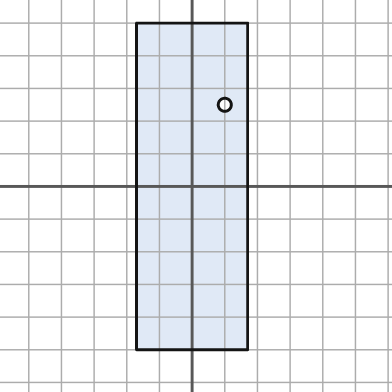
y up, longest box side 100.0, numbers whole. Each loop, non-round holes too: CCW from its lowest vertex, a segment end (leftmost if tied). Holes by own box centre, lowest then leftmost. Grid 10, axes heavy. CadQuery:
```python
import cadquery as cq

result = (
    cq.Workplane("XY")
    .moveTo(-17.0, -50.0)
    .lineTo(17.0, -50.0)
    .lineTo(17.0, 50.0)
    .lineTo(-17.0, 50.0)
    .close()
    .moveTo(10.0, 25.0)
    .circle(2.0)
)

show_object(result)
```